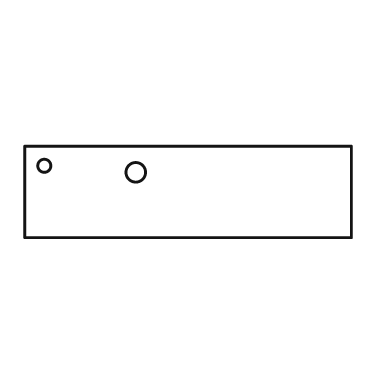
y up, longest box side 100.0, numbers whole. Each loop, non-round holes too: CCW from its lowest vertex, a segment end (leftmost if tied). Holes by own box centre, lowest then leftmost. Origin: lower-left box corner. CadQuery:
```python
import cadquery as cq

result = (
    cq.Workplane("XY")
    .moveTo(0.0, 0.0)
    .lineTo(100.0, 0.0)
    .lineTo(100.0, 28.0)
    .lineTo(0.0, 28.0)
    .close()
    .moveTo(34.0, 20.0)
    .circle(3.0)
    .moveTo(6.0, 22.0)
    .circle(2.0)
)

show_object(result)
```